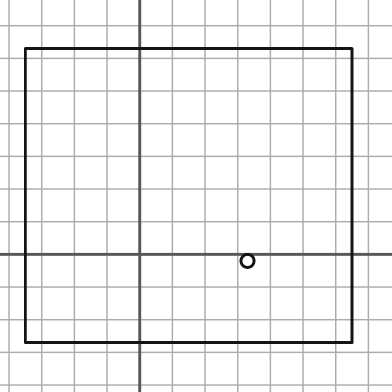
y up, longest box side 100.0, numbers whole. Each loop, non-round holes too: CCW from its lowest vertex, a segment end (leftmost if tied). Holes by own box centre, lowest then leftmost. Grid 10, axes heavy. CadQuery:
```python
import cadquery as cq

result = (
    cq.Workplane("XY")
    .moveTo(-35.0, -27.0)
    .lineTo(65.0, -27.0)
    .lineTo(65.0, 63.0)
    .lineTo(-35.0, 63.0)
    .close()
    .moveTo(33.0, -2.0)
    .circle(2.0)
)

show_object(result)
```